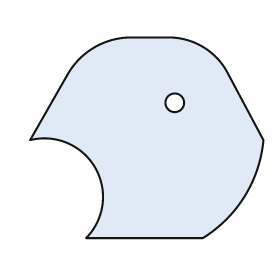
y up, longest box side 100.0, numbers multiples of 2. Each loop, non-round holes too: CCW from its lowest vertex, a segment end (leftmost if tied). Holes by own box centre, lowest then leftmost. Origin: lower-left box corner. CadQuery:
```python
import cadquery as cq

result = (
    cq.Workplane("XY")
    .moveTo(24.0, 0.0)
    .lineTo(74.0, 0.0)
    .threePointArc((92.0, 18.0), (100.0, 42.0))
    .lineTo(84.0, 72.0)
    .threePointArc((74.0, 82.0), (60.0, 86.0))
    .lineTo(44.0, 86.0)
    .threePointArc((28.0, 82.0), (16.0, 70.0))
    .lineTo(0.0, 42.0)
    .threePointArc((28.0, 30.0), (24.0, 0.0))
    .close()
    .moveTo(62.0, 58.0)
    .circle(4.0)
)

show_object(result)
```